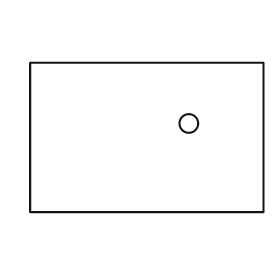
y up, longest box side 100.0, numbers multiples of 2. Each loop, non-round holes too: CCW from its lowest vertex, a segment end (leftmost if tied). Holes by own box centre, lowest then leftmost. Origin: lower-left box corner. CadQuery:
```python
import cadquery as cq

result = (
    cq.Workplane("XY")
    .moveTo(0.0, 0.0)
    .lineTo(100.0, 0.0)
    .lineTo(100.0, 64.0)
    .lineTo(0.0, 64.0)
    .close()
    .moveTo(68.0, 38.0)
    .circle(4.0)
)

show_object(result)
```